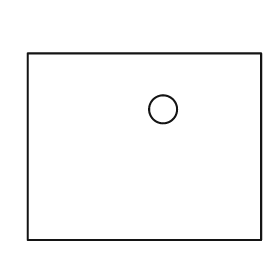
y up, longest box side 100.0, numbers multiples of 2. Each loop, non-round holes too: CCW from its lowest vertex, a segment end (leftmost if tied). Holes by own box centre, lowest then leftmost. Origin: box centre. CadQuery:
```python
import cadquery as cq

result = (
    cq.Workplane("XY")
    .moveTo(-50.0, -40.0)
    .lineTo(50.0, -40.0)
    .lineTo(50.0, 40.0)
    .lineTo(-50.0, 40.0)
    .close()
    .moveTo(8.0, 16.0)
    .circle(6.0)
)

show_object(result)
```